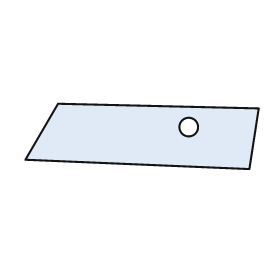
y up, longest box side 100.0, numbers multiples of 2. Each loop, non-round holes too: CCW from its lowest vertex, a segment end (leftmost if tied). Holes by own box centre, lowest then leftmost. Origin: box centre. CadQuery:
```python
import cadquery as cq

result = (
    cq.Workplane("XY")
    .moveTo(46.0, -14.0)
    .lineTo(50.0, 12.0)
    .lineTo(-36.0, 14.0)
    .lineTo(-50.0, -10.0)
    .close()
    .moveTo(20.0, 4.0)
    .circle(4.0)
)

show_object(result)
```